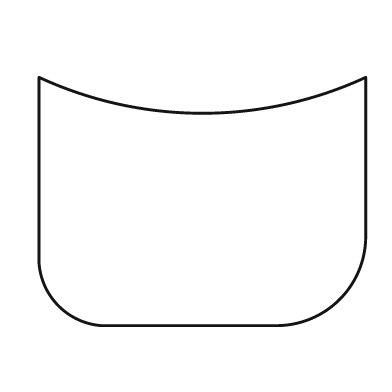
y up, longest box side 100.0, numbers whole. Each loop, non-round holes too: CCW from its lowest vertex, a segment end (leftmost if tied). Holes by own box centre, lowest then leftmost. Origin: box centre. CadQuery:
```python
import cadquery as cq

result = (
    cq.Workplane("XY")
    .moveTo(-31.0, -38.0)
    .lineTo(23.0, -38.0)
    .threePointArc((42.0, -30.0), (50.0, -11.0))
    .lineTo(50.0, 38.0)
    .threePointArc((0.0, 27.0), (-50.0, 38.0))
    .lineTo(-50.0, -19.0)
    .threePointArc((-44.0, -32.0), (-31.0, -38.0))
    .close()
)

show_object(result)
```